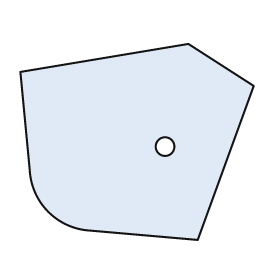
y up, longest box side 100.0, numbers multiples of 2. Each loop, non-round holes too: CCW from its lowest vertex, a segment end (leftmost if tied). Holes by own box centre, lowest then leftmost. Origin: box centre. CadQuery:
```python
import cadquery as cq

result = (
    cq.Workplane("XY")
    .moveTo(26.0, -42.0)
    .lineTo(50.0, 24.0)
    .lineTo(22.0, 42.0)
    .lineTo(-50.0, 30.0)
    .lineTo(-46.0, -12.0)
    .threePointArc((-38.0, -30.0), (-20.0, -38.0))
    .close()
    .moveTo(12.0, -2.0)
    .circle(4.0)
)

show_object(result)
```